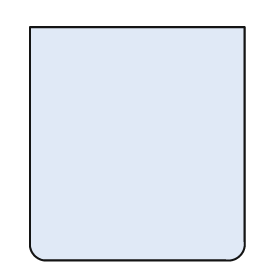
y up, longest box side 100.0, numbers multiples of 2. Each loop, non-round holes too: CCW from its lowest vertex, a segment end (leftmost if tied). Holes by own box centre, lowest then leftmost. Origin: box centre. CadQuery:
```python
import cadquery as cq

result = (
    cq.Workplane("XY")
    .moveTo(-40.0, -50.0)
    .lineTo(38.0, -50.0)
    .threePointArc((44.0, -48.0), (46.0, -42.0))
    .lineTo(46.0, 50.0)
    .lineTo(-46.0, 50.0)
    .lineTo(-46.0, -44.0)
    .threePointArc((-44.0, -48.0), (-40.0, -50.0))
    .close()
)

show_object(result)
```